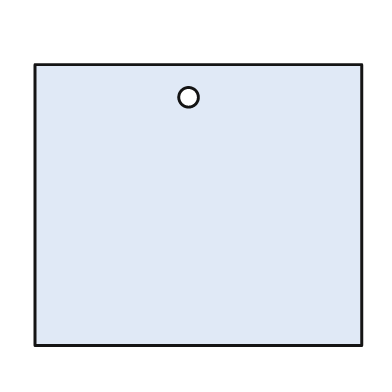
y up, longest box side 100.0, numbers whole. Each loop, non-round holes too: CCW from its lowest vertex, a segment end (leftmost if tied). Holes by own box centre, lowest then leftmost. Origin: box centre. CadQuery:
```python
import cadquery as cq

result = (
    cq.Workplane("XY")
    .moveTo(-50.0, -43.0)
    .lineTo(50.0, -43.0)
    .lineTo(50.0, 43.0)
    .lineTo(-50.0, 43.0)
    .close()
    .moveTo(-3.0, 33.0)
    .circle(3.0)
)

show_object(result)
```